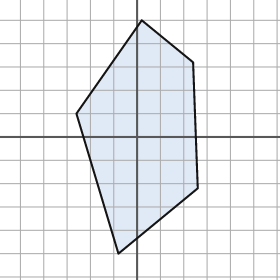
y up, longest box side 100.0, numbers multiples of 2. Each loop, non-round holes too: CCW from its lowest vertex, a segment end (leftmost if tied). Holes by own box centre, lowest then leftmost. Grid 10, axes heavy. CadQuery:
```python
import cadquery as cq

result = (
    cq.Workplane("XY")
    .moveTo(-8.0, -50.0)
    .lineTo(26.0, -22.0)
    .lineTo(24.0, 32.0)
    .lineTo(2.0, 50.0)
    .lineTo(-26.0, 10.0)
    .close()
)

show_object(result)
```